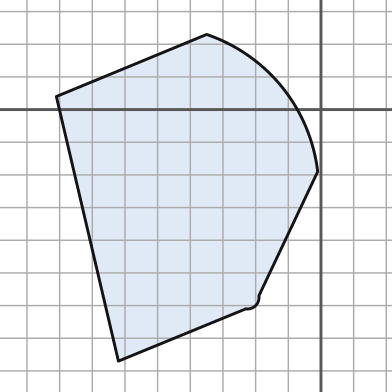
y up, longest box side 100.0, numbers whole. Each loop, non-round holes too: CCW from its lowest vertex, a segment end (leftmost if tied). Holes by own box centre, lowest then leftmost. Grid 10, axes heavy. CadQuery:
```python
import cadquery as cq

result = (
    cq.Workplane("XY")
    .moveTo(-62.0, -77.0)
    .lineTo(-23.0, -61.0)
    .threePointArc((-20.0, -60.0), (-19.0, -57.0))
    .lineTo(-1.0, -19.0)
    .threePointArc((-12.0, 7.0), (-35.0, 23.0))
    .lineTo(-81.0, 4.0)
    .close()
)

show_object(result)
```